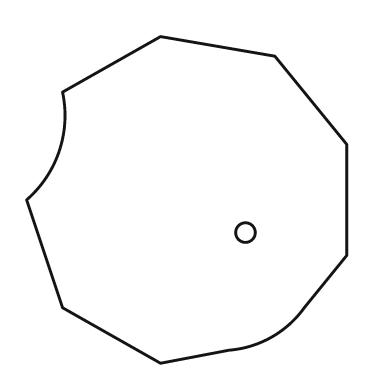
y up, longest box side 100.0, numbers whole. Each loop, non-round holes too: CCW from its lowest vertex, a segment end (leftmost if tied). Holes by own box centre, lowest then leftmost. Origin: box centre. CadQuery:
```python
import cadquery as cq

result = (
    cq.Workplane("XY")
    .moveTo(-8.0, -50.0)
    .lineTo(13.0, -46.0)
    .threePointArc((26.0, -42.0), (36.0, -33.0))
    .lineTo(49.0, -17.0)
    .lineTo(49.0, 17.0)
    .lineTo(27.0, 44.0)
    .lineTo(-8.0, 50.0)
    .lineTo(-38.0, 33.0)
    .threePointArc((-39.0, 15.0), (-49.0, 0.0))
    .lineTo(-38.0, -33.0)
    .close()
    .moveTo(18.0, -10.0)
    .circle(3.0)
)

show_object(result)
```